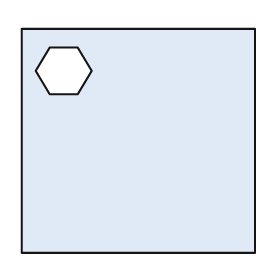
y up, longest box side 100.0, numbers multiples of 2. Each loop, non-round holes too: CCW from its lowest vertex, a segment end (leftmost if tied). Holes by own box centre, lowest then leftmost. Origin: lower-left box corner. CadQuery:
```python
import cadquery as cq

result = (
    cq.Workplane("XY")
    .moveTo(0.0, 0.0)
    .lineTo(100.0, 0.0)
    .lineTo(100.0, 96.0)
    .lineTo(0.0, 96.0)
    .close()
    .moveTo(12.0, 68.0)
    .lineTo(24.0, 68.0)
    .lineTo(30.0, 78.0)
    .lineTo(24.0, 88.0)
    .lineTo(12.0, 88.0)
    .lineTo(6.0, 78.0)
    .close()
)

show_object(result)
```